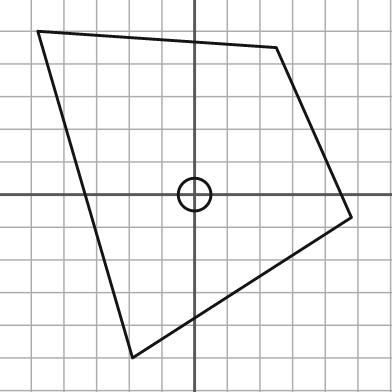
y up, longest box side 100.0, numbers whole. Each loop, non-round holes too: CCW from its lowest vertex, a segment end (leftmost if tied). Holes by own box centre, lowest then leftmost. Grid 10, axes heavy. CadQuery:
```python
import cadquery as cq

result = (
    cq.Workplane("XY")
    .moveTo(-19.0, -50.0)
    .lineTo(48.0, -7.0)
    .lineTo(25.0, 45.0)
    .lineTo(-48.0, 50.0)
    .close()
    .moveTo(0.0, 0.0)
    .circle(5.0)
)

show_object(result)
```